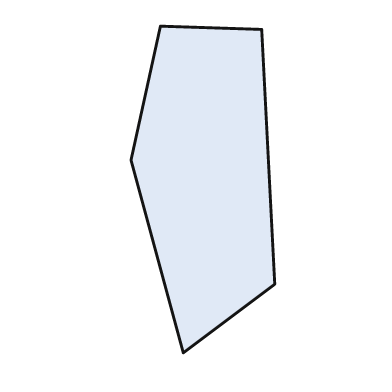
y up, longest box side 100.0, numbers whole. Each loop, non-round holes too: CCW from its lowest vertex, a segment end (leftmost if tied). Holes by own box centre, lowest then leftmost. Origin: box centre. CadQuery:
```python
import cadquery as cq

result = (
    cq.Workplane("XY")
    .moveTo(-6.0, -50.0)
    .lineTo(22.0, -29.0)
    .lineTo(18.0, 49.0)
    .lineTo(-13.0, 50.0)
    .lineTo(-22.0, 9.0)
    .close()
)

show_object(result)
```